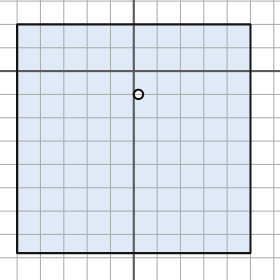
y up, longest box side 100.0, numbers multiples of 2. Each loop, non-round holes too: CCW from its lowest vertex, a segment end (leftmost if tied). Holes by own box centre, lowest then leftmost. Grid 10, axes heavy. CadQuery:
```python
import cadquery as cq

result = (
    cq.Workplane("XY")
    .moveTo(-50.0, -78.0)
    .lineTo(50.0, -78.0)
    .lineTo(50.0, 20.0)
    .lineTo(-50.0, 20.0)
    .close()
    .moveTo(2.0, -10.0)
    .circle(2.0)
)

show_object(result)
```